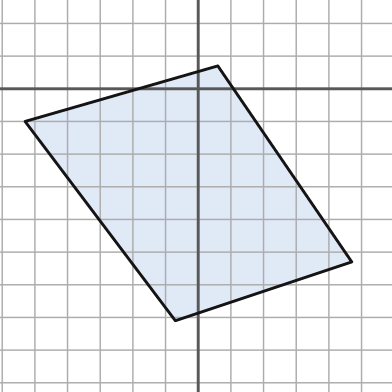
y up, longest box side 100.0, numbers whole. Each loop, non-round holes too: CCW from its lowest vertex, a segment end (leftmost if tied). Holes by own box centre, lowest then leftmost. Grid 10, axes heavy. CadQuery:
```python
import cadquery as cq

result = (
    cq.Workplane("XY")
    .moveTo(-7.0, -71.0)
    .lineTo(47.0, -53.0)
    .lineTo(6.0, 7.0)
    .lineTo(-53.0, -10.0)
    .close()
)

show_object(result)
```